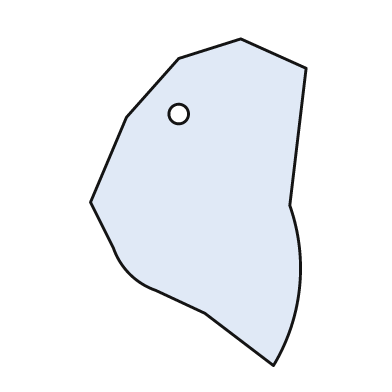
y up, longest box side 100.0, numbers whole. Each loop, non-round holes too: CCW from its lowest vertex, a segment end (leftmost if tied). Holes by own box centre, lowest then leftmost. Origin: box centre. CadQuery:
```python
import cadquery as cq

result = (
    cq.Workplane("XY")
    .moveTo(23.0, -50.0)
    .threePointArc((31.0, -26.0), (28.0, -1.0))
    .lineTo(33.0, 41.0)
    .lineTo(13.0, 50.0)
    .lineTo(-6.0, 44.0)
    .lineTo(-22.0, 26.0)
    .lineTo(-33.0, 0.0)
    .lineTo(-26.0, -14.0)
    .threePointArc((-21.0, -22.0), (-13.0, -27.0))
    .lineTo(2.0, -34.0)
    .close()
    .moveTo(-6.0, 27.0)
    .circle(3.0)
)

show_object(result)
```